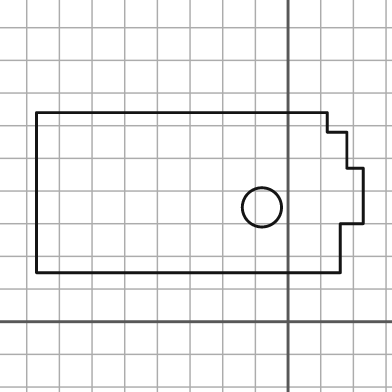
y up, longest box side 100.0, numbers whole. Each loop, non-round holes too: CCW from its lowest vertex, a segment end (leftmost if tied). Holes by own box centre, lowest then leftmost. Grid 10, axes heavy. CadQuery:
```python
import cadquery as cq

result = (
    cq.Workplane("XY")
    .moveTo(-77.0, 15.0)
    .lineTo(16.0, 15.0)
    .lineTo(16.0, 30.0)
    .lineTo(23.0, 30.0)
    .lineTo(23.0, 47.0)
    .lineTo(18.0, 47.0)
    .lineTo(18.0, 58.0)
    .lineTo(12.0, 58.0)
    .lineTo(12.0, 64.0)
    .lineTo(-77.0, 64.0)
    .close()
    .moveTo(-8.0, 35.0)
    .circle(6.0)
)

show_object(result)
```